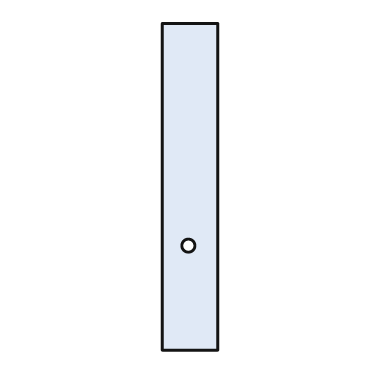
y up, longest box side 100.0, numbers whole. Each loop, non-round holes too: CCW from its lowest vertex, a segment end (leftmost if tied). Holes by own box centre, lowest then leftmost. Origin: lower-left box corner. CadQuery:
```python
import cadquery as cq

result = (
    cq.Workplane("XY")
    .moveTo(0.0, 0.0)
    .lineTo(17.0, 0.0)
    .lineTo(17.0, 100.0)
    .lineTo(0.0, 100.0)
    .close()
    .moveTo(8.0, 32.0)
    .circle(2.0)
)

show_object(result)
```